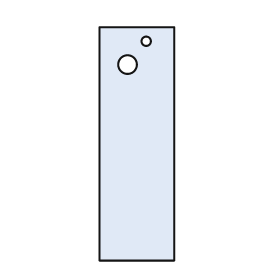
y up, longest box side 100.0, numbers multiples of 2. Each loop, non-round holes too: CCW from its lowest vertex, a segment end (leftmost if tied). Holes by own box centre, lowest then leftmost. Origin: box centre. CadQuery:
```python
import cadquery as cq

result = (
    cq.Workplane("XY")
    .moveTo(-16.0, -50.0)
    .lineTo(16.0, -50.0)
    .lineTo(16.0, 50.0)
    .lineTo(-16.0, 50.0)
    .close()
    .moveTo(-4.0, 34.0)
    .circle(4.0)
    .moveTo(4.0, 44.0)
    .circle(2.0)
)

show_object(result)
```